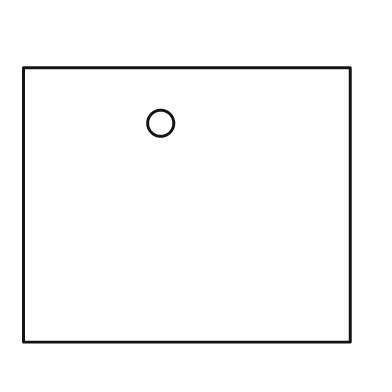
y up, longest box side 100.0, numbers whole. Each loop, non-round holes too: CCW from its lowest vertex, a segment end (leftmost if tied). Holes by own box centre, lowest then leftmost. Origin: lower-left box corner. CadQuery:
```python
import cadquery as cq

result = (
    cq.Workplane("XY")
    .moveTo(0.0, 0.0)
    .lineTo(100.0, 0.0)
    .lineTo(100.0, 84.0)
    .lineTo(0.0, 84.0)
    .close()
    .moveTo(42.0, 67.0)
    .circle(4.0)
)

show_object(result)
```